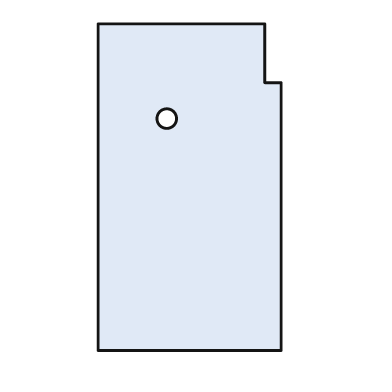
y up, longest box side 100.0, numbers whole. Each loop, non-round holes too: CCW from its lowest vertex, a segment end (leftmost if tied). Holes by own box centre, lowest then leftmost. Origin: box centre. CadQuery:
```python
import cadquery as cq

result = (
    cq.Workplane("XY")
    .moveTo(-28.0, -50.0)
    .lineTo(28.0, -50.0)
    .lineTo(28.0, 32.0)
    .lineTo(23.0, 32.0)
    .lineTo(23.0, 50.0)
    .lineTo(-28.0, 50.0)
    .close()
    .moveTo(-7.0, 21.0)
    .circle(3.0)
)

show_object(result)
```